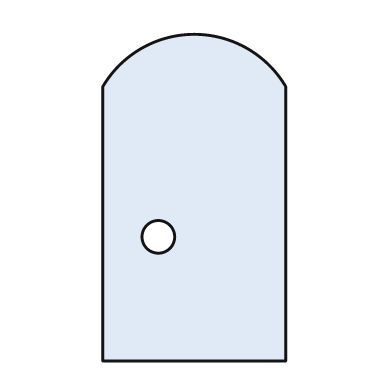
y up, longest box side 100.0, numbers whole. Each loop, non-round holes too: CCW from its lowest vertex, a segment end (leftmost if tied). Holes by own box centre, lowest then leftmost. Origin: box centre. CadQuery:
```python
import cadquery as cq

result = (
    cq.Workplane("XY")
    .moveTo(-28.0, -50.0)
    .lineTo(28.0, -50.0)
    .lineTo(28.0, 34.0)
    .threePointArc((0.0, 50.0), (-28.0, 34.0))
    .close()
    .moveTo(-11.0, -12.0)
    .circle(5.0)
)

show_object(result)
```